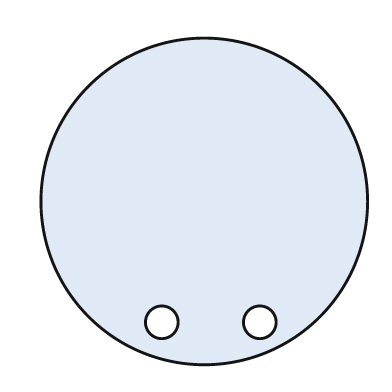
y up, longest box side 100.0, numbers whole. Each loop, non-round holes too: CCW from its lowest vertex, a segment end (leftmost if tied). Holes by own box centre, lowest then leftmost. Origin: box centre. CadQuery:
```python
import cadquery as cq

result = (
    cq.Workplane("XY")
    .moveTo(0.0, 0.0)
    .circle(50.0)
    .moveTo(-13.0, -37.0)
    .circle(5.0)
    .moveTo(17.0, -37.0)
    .circle(5.0)
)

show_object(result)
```